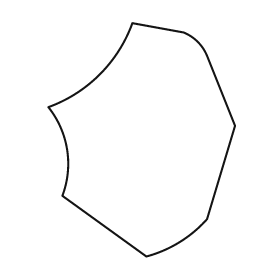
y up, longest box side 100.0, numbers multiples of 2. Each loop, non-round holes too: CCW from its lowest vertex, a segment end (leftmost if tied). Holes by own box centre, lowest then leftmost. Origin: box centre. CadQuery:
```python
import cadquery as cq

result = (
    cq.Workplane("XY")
    .moveTo(2.0, -50.0)
    .threePointArc((16.0, -44.0), (28.0, -34.0))
    .lineTo(40.0, 6.0)
    .lineTo(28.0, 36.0)
    .threePointArc((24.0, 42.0), (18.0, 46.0))
    .lineTo(-4.0, 50.0)
    .threePointArc((-18.0, 28.0), (-40.0, 14.0))
    .threePointArc((-32.0, -4.0), (-34.0, -24.0))
    .close()
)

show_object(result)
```